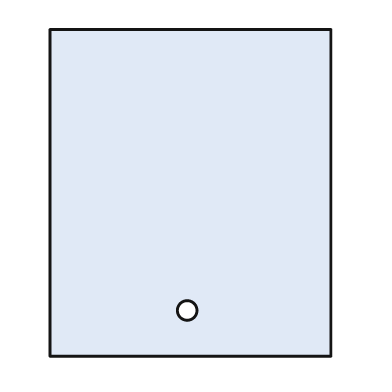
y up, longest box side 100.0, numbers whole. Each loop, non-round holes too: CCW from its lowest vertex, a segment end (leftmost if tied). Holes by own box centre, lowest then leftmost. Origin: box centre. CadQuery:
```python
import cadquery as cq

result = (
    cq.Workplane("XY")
    .moveTo(-43.0, -50.0)
    .lineTo(43.0, -50.0)
    .lineTo(43.0, 50.0)
    .lineTo(-43.0, 50.0)
    .close()
    .moveTo(-1.0, -36.0)
    .circle(3.0)
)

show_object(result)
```